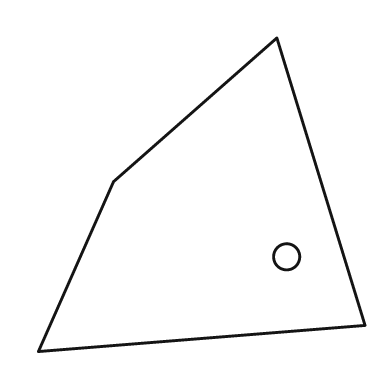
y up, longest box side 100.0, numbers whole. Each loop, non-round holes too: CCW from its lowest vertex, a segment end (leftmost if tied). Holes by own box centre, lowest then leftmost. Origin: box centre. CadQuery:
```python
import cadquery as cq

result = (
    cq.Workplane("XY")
    .moveTo(-50.0, -48.0)
    .lineTo(50.0, -40.0)
    .lineTo(23.0, 48.0)
    .lineTo(-27.0, 4.0)
    .close()
    .moveTo(26.0, -19.0)
    .circle(4.0)
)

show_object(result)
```